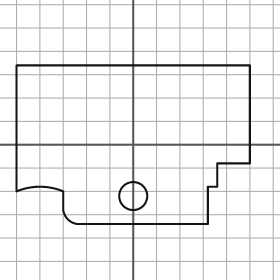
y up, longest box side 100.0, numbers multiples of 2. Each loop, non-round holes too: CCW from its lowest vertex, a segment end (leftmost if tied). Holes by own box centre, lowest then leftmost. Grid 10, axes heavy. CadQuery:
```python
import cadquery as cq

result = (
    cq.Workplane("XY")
    .moveTo(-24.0, -34.0)
    .lineTo(32.0, -34.0)
    .lineTo(32.0, -18.0)
    .lineTo(36.0, -18.0)
    .lineTo(36.0, -8.0)
    .lineTo(50.0, -8.0)
    .lineTo(50.0, 34.0)
    .lineTo(-50.0, 34.0)
    .lineTo(-50.0, -20.0)
    .threePointArc((-40.0, -18.0), (-30.0, -20.0))
    .lineTo(-30.0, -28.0)
    .threePointArc((-28.0, -32.0), (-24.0, -34.0))
    .close()
    .moveTo(0.0, -22.0)
    .circle(6.0)
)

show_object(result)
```